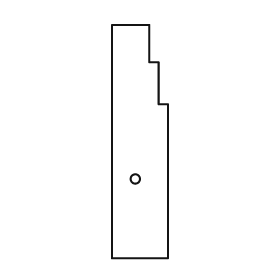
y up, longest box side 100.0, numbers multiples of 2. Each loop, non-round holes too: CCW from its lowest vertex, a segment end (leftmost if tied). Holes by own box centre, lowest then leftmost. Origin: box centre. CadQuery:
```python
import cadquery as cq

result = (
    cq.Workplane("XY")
    .moveTo(-12.0, -50.0)
    .lineTo(12.0, -50.0)
    .lineTo(12.0, 16.0)
    .lineTo(8.0, 16.0)
    .lineTo(8.0, 34.0)
    .lineTo(4.0, 34.0)
    .lineTo(4.0, 50.0)
    .lineTo(-12.0, 50.0)
    .close()
    .moveTo(-2.0, -16.0)
    .circle(2.0)
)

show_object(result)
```